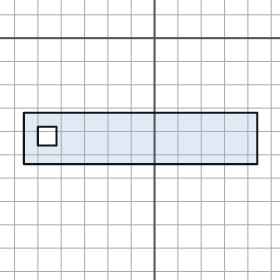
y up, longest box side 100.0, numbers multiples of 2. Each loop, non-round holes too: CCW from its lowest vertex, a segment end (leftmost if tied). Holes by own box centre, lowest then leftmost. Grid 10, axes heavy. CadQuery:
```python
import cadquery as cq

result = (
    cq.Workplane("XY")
    .moveTo(-56.0, -54.0)
    .lineTo(44.0, -54.0)
    .lineTo(44.0, -32.0)
    .lineTo(-56.0, -32.0)
    .close()
    .moveTo(-50.0, -46.0)
    .lineTo(-42.0, -46.0)
    .lineTo(-42.0, -38.0)
    .lineTo(-50.0, -38.0)
    .close()
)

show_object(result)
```